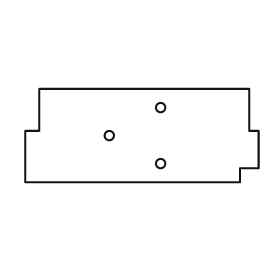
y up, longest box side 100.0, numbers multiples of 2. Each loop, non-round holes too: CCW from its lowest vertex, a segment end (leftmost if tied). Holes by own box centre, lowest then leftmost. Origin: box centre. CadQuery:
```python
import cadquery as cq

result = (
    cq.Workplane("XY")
    .moveTo(-50.0, -20.0)
    .lineTo(42.0, -20.0)
    .lineTo(42.0, -14.0)
    .lineTo(50.0, -14.0)
    .lineTo(50.0, 2.0)
    .lineTo(46.0, 2.0)
    .lineTo(46.0, 20.0)
    .lineTo(-44.0, 20.0)
    .lineTo(-44.0, 2.0)
    .lineTo(-50.0, 2.0)
    .close()
    .moveTo(8.0, -12.0)
    .circle(2.0)
    .moveTo(-14.0, 0.0)
    .circle(2.0)
    .moveTo(8.0, 12.0)
    .circle(2.0)
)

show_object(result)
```